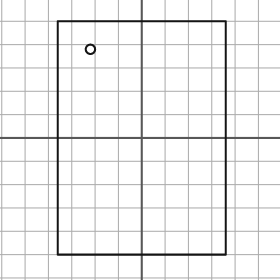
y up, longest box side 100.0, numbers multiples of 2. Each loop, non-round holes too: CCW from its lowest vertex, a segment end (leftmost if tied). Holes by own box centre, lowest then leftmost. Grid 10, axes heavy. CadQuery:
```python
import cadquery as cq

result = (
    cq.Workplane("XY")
    .moveTo(-36.0, -50.0)
    .lineTo(36.0, -50.0)
    .lineTo(36.0, 50.0)
    .lineTo(-36.0, 50.0)
    .close()
    .moveTo(-22.0, 38.0)
    .circle(2.0)
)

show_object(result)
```